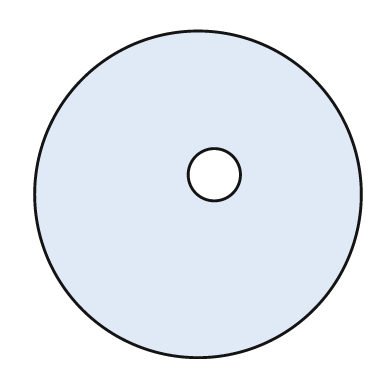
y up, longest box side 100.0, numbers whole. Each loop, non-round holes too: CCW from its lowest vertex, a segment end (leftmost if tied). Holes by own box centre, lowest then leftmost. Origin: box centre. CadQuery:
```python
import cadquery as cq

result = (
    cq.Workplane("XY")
    .moveTo(0.0, 0.0)
    .circle(50.0)
    .moveTo(5.0, 6.0)
    .circle(8.0)
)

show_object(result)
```